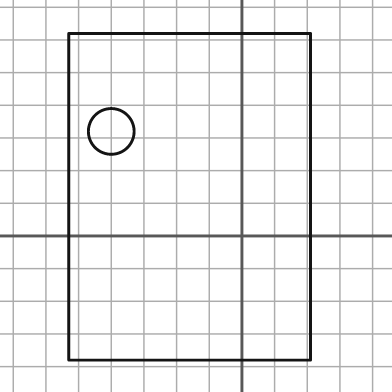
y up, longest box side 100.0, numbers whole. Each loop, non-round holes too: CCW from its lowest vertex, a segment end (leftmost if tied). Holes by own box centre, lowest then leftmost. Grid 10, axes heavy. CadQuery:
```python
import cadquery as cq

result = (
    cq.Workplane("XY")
    .moveTo(-53.0, -38.0)
    .lineTo(21.0, -38.0)
    .lineTo(21.0, 62.0)
    .lineTo(-53.0, 62.0)
    .close()
    .moveTo(-40.0, 32.0)
    .circle(7.0)
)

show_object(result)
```